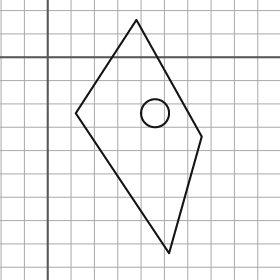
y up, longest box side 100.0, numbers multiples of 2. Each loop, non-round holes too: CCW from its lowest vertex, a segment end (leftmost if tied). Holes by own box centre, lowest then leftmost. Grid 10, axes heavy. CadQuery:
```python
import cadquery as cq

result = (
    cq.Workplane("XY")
    .moveTo(52.0, -84.0)
    .lineTo(66.0, -34.0)
    .lineTo(38.0, 16.0)
    .lineTo(12.0, -24.0)
    .close()
    .moveTo(46.0, -24.0)
    .circle(6.0)
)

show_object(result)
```